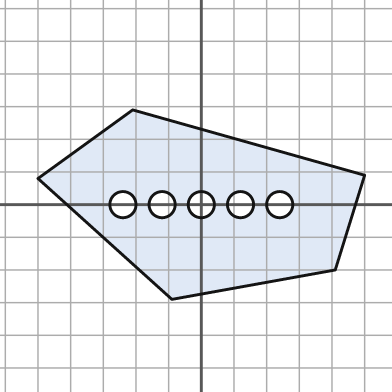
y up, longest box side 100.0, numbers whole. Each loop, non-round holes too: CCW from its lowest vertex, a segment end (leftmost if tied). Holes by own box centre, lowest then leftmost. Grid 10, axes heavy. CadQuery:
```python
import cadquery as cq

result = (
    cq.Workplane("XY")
    .moveTo(-9.0, -29.0)
    .lineTo(41.0, -20.0)
    .lineTo(50.0, 9.0)
    .lineTo(-21.0, 29.0)
    .lineTo(-50.0, 8.0)
    .close()
    .moveTo(-24.0, 0.0)
    .circle(4.0)
    .moveTo(-12.0, 0.0)
    .circle(4.0)
    .moveTo(0.0, 0.0)
    .circle(4.0)
    .moveTo(12.0, 0.0)
    .circle(4.0)
    .moveTo(24.0, 0.0)
    .circle(4.0)
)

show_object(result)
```